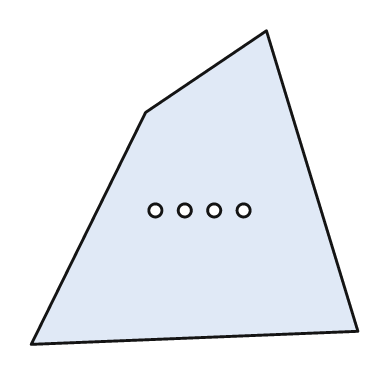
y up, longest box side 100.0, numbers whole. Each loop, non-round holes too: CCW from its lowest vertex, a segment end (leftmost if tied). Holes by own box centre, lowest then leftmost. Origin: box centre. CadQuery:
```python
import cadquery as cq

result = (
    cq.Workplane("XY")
    .moveTo(-50.0, -48.0)
    .lineTo(50.0, -44.0)
    .lineTo(22.0, 48.0)
    .lineTo(-15.0, 23.0)
    .close()
    .moveTo(-12.0, -7.0)
    .circle(2.0)
    .moveTo(-3.0, -7.0)
    .circle(2.0)
    .moveTo(6.0, -7.0)
    .circle(2.0)
    .moveTo(15.0, -7.0)
    .circle(2.0)
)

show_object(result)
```